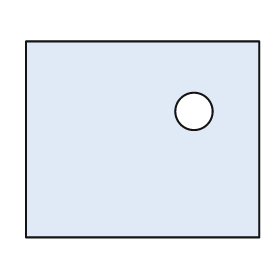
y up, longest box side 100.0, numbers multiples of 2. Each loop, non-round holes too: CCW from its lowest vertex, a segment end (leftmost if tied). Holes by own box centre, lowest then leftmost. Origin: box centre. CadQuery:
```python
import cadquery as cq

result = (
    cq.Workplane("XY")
    .moveTo(-50.0, -42.0)
    .lineTo(50.0, -42.0)
    .lineTo(50.0, 42.0)
    .lineTo(-50.0, 42.0)
    .close()
    .moveTo(22.0, 12.0)
    .circle(8.0)
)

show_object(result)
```